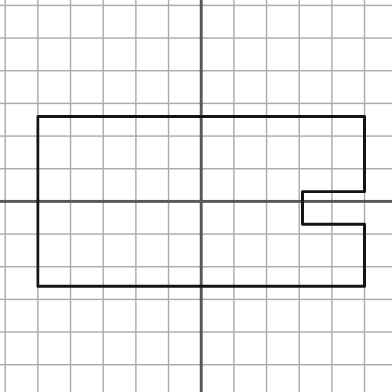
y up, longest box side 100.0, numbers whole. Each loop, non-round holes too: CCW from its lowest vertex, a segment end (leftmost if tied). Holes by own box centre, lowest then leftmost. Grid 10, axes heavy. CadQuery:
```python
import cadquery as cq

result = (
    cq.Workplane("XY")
    .moveTo(-50.0, -26.0)
    .lineTo(50.0, -26.0)
    .lineTo(50.0, -7.0)
    .lineTo(31.0, -7.0)
    .lineTo(31.0, 3.0)
    .lineTo(50.0, 3.0)
    .lineTo(50.0, 26.0)
    .lineTo(-50.0, 26.0)
    .close()
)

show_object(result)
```